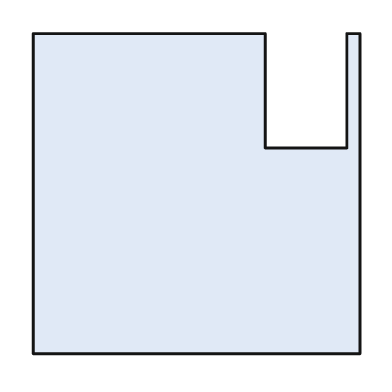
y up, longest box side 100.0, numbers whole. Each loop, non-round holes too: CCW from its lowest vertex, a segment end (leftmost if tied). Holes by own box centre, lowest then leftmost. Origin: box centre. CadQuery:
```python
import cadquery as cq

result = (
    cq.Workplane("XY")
    .moveTo(-50.0, -49.0)
    .lineTo(50.0, -49.0)
    .lineTo(50.0, 49.0)
    .lineTo(46.0, 49.0)
    .lineTo(46.0, 14.0)
    .lineTo(21.0, 14.0)
    .lineTo(21.0, 49.0)
    .lineTo(-50.0, 49.0)
    .close()
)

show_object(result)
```